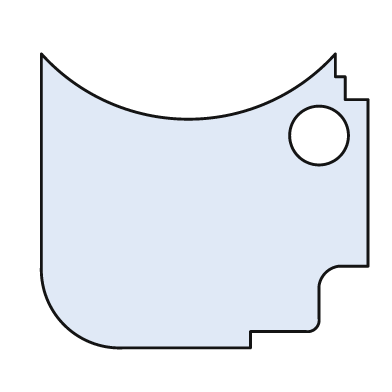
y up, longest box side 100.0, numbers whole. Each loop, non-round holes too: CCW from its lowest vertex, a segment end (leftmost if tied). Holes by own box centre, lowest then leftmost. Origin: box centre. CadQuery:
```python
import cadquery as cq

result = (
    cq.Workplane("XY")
    .moveTo(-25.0, -45.0)
    .lineTo(14.0, -45.0)
    .lineTo(14.0, -40.0)
    .lineTo(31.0, -40.0)
    .threePointArc((34.0, -39.0), (35.0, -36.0))
    .lineTo(35.0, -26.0)
    .threePointArc((37.0, -22.0), (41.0, -20.0))
    .lineTo(50.0, -20.0)
    .lineTo(50.0, 31.0)
    .lineTo(43.0, 31.0)
    .lineTo(43.0, 38.0)
    .lineTo(40.0, 38.0)
    .lineTo(40.0, 45.0)
    .threePointArc((-5.0, 25.0), (-50.0, 45.0))
    .lineTo(-50.0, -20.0)
    .threePointArc((-43.0, -38.0), (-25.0, -45.0))
    .close()
    .moveTo(35.0, 20.0)
    .circle(9.0)
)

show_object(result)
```